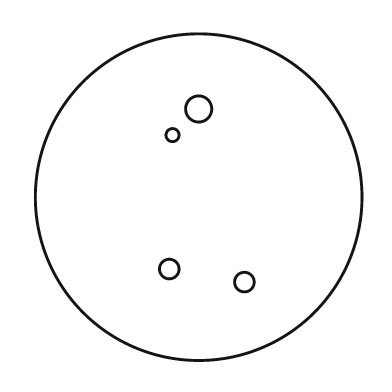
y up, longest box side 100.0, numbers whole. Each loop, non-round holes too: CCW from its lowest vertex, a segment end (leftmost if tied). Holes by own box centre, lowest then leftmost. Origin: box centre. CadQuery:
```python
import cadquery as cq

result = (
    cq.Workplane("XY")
    .moveTo(0.0, 0.0)
    .circle(50.0)
    .moveTo(14.0, -26.0)
    .circle(3.0)
    .moveTo(-9.0, -22.0)
    .circle(3.0)
    .moveTo(-8.0, 19.0)
    .circle(2.0)
    .moveTo(0.0, 27.0)
    .circle(4.0)
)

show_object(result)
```